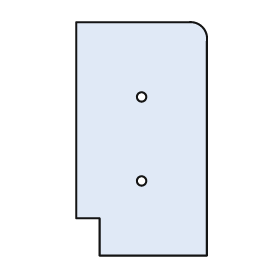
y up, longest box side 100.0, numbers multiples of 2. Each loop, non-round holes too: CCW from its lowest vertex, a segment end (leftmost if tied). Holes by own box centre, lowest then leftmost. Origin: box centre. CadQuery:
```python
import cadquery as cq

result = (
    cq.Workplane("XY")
    .moveTo(-18.0, -50.0)
    .lineTo(28.0, -50.0)
    .lineTo(28.0, 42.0)
    .threePointArc((26.0, 48.0), (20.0, 50.0))
    .lineTo(-28.0, 50.0)
    .lineTo(-28.0, -34.0)
    .lineTo(-18.0, -34.0)
    .close()
    .moveTo(0.0, -18.0)
    .circle(2.0)
    .moveTo(0.0, 18.0)
    .circle(2.0)
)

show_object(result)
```